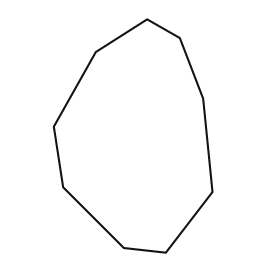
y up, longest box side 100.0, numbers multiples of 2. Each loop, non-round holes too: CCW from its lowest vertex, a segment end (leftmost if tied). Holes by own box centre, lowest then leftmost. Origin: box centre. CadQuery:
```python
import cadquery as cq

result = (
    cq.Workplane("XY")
    .moveTo(14.0, -50.0)
    .lineTo(34.0, -24.0)
    .lineTo(30.0, 16.0)
    .lineTo(20.0, 42.0)
    .lineTo(6.0, 50.0)
    .lineTo(-16.0, 36.0)
    .lineTo(-34.0, 4.0)
    .lineTo(-30.0, -22.0)
    .lineTo(-4.0, -48.0)
    .close()
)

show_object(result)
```